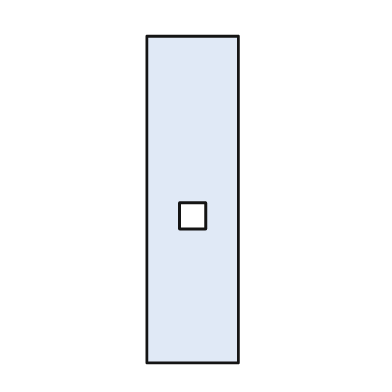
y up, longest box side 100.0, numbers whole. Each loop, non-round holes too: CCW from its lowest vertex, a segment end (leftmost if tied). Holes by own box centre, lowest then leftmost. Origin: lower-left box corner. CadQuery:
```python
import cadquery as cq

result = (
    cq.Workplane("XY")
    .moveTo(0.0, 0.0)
    .lineTo(28.0, 0.0)
    .lineTo(28.0, 100.0)
    .lineTo(0.0, 100.0)
    .close()
    .moveTo(10.0, 41.0)
    .lineTo(18.0, 41.0)
    .lineTo(18.0, 49.0)
    .lineTo(10.0, 49.0)
    .close()
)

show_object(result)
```